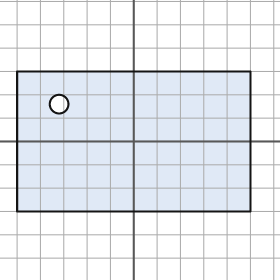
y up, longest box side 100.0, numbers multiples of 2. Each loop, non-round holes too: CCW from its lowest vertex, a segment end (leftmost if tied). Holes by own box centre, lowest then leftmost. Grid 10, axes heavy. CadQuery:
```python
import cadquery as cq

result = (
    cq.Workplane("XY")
    .moveTo(-50.0, -30.0)
    .lineTo(50.0, -30.0)
    .lineTo(50.0, 30.0)
    .lineTo(-50.0, 30.0)
    .close()
    .moveTo(-32.0, 16.0)
    .circle(4.0)
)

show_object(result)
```